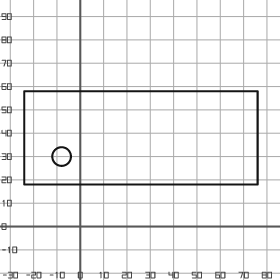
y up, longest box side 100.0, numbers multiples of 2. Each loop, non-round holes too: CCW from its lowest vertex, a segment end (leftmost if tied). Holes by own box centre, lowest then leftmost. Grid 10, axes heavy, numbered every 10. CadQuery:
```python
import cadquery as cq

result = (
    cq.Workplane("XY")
    .moveTo(-24.0, 18.0)
    .lineTo(76.0, 18.0)
    .lineTo(76.0, 58.0)
    .lineTo(-24.0, 58.0)
    .close()
    .moveTo(-8.0, 30.0)
    .circle(4.0)
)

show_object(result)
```